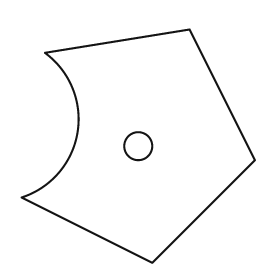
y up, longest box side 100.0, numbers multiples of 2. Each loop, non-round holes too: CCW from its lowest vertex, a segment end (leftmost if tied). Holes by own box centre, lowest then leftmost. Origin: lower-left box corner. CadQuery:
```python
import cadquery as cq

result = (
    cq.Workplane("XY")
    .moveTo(56.0, 0.0)
    .lineTo(100.0, 44.0)
    .lineTo(72.0, 100.0)
    .lineTo(10.0, 90.0)
    .threePointArc((24.0, 56.0), (0.0, 28.0))
    .close()
    .moveTo(50.0, 50.0)
    .circle(6.0)
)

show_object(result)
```